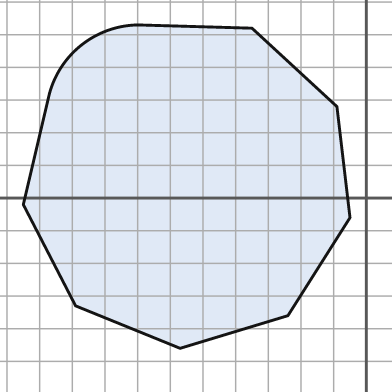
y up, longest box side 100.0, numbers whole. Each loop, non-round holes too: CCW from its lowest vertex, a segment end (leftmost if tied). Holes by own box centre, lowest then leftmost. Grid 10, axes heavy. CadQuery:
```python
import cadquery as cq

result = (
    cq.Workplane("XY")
    .moveTo(-57.0, -46.0)
    .lineTo(-24.0, -36.0)
    .lineTo(-5.0, -6.0)
    .lineTo(-9.0, 28.0)
    .lineTo(-35.0, 52.0)
    .lineTo(-70.0, 53.0)
    .threePointArc((-87.0, 47.0), (-97.0, 32.0))
    .lineTo(-105.0, -2.0)
    .lineTo(-89.0, -33.0)
    .close()
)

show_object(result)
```